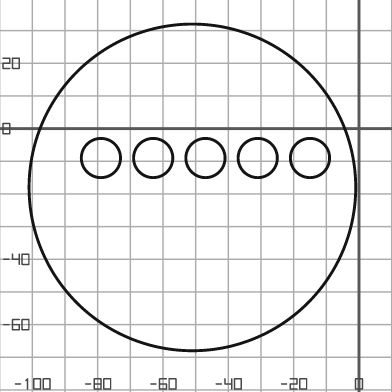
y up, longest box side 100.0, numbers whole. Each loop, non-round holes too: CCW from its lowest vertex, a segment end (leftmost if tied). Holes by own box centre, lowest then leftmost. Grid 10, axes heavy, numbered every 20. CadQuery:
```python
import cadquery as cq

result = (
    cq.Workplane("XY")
    .moveTo(-51.0, -18.0)
    .circle(50.0)
    .moveTo(-79.0, -9.0)
    .circle(6.0)
    .moveTo(-63.0, -9.0)
    .circle(6.0)
    .moveTo(-47.0, -9.0)
    .circle(6.0)
    .moveTo(-31.0, -9.0)
    .circle(6.0)
    .moveTo(-15.0, -9.0)
    .circle(6.0)
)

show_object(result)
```